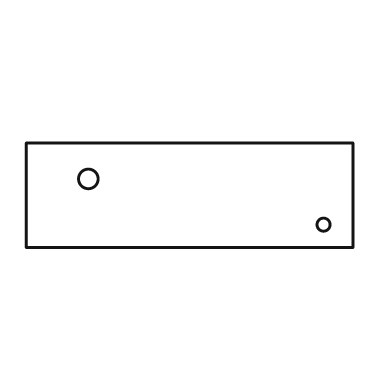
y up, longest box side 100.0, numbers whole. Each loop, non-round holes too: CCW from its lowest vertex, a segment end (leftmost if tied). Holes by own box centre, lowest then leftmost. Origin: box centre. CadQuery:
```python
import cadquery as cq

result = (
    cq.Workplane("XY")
    .moveTo(-50.0, -16.0)
    .lineTo(50.0, -16.0)
    .lineTo(50.0, 16.0)
    .lineTo(-50.0, 16.0)
    .close()
    .moveTo(41.0, -9.0)
    .circle(2.0)
    .moveTo(-31.0, 5.0)
    .circle(3.0)
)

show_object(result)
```